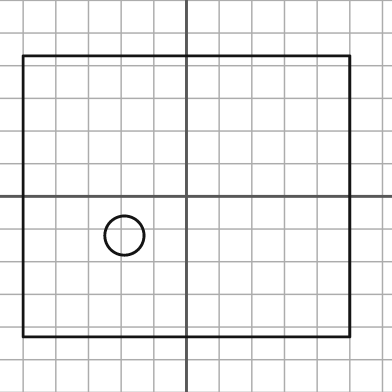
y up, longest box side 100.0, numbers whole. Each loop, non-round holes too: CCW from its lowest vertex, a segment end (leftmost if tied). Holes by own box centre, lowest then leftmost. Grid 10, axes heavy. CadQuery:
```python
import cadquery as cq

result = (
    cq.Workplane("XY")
    .moveTo(-50.0, -43.0)
    .lineTo(50.0, -43.0)
    .lineTo(50.0, 43.0)
    .lineTo(-50.0, 43.0)
    .close()
    .moveTo(-19.0, -12.0)
    .circle(6.0)
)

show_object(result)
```